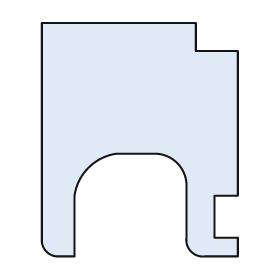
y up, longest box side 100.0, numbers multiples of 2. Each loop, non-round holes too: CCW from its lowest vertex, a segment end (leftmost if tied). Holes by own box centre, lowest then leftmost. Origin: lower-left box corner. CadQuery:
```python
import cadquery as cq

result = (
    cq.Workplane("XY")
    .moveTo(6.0, 0.0)
    .lineTo(14.0, 0.0)
    .lineTo(14.0, 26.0)
    .threePointArc((20.0, 38.0), (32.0, 44.0))
    .lineTo(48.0, 44.0)
    .threePointArc((58.0, 40.0), (62.0, 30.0))
    .lineTo(62.0, 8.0)
    .threePointArc((64.0, 2.0), (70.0, 0.0))
    .lineTo(84.0, 0.0)
    .lineTo(84.0, 8.0)
    .lineTo(74.0, 8.0)
    .lineTo(74.0, 26.0)
    .lineTo(84.0, 26.0)
    .lineTo(84.0, 88.0)
    .lineTo(66.0, 88.0)
    .lineTo(66.0, 100.0)
    .lineTo(0.0, 100.0)
    .lineTo(0.0, 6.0)
    .threePointArc((2.0, 2.0), (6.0, 0.0))
    .close()
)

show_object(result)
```